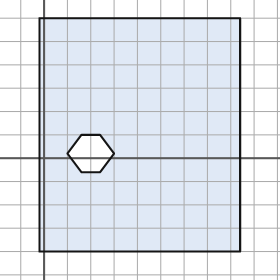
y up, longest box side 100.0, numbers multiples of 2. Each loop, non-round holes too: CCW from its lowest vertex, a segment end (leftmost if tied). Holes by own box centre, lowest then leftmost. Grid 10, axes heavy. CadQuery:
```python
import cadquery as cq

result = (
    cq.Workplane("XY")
    .moveTo(-2.0, -40.0)
    .lineTo(84.0, -40.0)
    .lineTo(84.0, 60.0)
    .lineTo(-2.0, 60.0)
    .close()
    .moveTo(16.0, -6.0)
    .lineTo(24.0, -6.0)
    .lineTo(30.0, 2.0)
    .lineTo(24.0, 10.0)
    .lineTo(16.0, 10.0)
    .lineTo(10.0, 2.0)
    .close()
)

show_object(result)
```